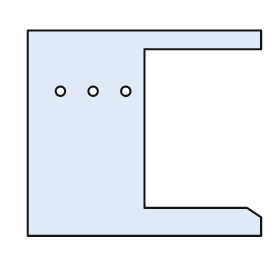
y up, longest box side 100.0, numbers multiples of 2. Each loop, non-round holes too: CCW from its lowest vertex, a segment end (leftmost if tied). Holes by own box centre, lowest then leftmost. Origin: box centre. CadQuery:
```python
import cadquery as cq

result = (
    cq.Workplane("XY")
    .moveTo(-50.0, -44.0)
    .lineTo(50.0, -44.0)
    .lineTo(50.0, -36.0)
    .lineTo(44.0, -32.0)
    .lineTo(0.0, -32.0)
    .lineTo(0.0, 36.0)
    .lineTo(50.0, 36.0)
    .lineTo(50.0, 44.0)
    .lineTo(-50.0, 44.0)
    .close()
    .moveTo(-36.0, 18.0)
    .circle(2.0)
    .moveTo(-22.0, 18.0)
    .circle(2.0)
    .moveTo(-8.0, 18.0)
    .circle(2.0)
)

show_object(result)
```